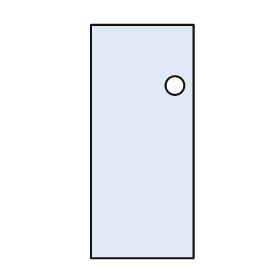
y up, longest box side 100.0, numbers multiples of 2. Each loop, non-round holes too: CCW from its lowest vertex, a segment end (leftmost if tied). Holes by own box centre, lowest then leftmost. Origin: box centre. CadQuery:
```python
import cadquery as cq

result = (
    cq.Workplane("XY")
    .moveTo(-22.0, -50.0)
    .lineTo(22.0, -50.0)
    .lineTo(22.0, 50.0)
    .lineTo(-22.0, 50.0)
    .close()
    .moveTo(14.0, 24.0)
    .circle(4.0)
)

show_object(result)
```